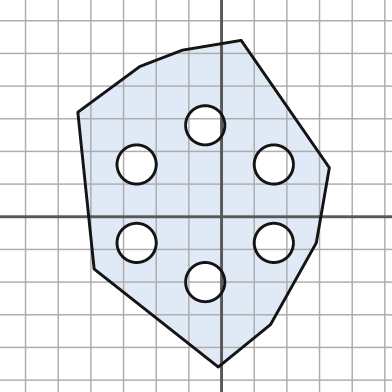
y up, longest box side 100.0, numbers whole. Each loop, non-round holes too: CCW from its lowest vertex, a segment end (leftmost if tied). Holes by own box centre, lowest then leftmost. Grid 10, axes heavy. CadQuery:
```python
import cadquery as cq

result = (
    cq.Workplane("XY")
    .moveTo(-1.0, -46.0)
    .lineTo(15.0, -33.0)
    .lineTo(29.0, -8.0)
    .lineTo(33.0, 15.0)
    .lineTo(6.0, 54.0)
    .lineTo(-12.0, 51.0)
    .lineTo(-25.0, 46.0)
    .lineTo(-44.0, 32.0)
    .lineTo(-39.0, -16.0)
    .close()
    .moveTo(-5.0, -20.0)
    .circle(6.0)
    .moveTo(-26.0, -8.0)
    .circle(6.0)
    .moveTo(16.0, -8.0)
    .circle(6.0)
    .moveTo(-26.0, 16.0)
    .circle(6.0)
    .moveTo(16.0, 16.0)
    .circle(6.0)
    .moveTo(-5.0, 28.0)
    .circle(6.0)
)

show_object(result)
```